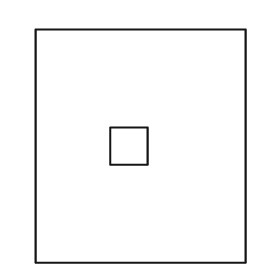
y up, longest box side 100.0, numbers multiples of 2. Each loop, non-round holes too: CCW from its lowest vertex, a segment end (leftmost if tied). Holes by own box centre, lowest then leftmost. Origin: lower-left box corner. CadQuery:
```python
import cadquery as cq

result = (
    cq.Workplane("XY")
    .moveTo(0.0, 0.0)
    .lineTo(90.0, 0.0)
    .lineTo(90.0, 100.0)
    .lineTo(0.0, 100.0)
    .close()
    .moveTo(32.0, 42.0)
    .lineTo(48.0, 42.0)
    .lineTo(48.0, 58.0)
    .lineTo(32.0, 58.0)
    .close()
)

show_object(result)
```